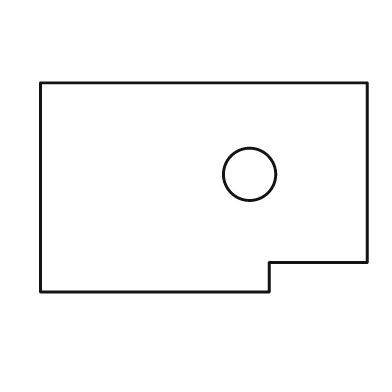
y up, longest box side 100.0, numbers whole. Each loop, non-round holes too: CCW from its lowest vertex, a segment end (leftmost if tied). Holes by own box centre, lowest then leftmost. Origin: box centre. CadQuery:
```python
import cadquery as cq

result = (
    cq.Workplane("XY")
    .moveTo(-50.0, -32.0)
    .lineTo(20.0, -32.0)
    .lineTo(20.0, -23.0)
    .lineTo(50.0, -23.0)
    .lineTo(50.0, 32.0)
    .lineTo(-50.0, 32.0)
    .close()
    .moveTo(14.0, 4.0)
    .circle(8.0)
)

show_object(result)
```